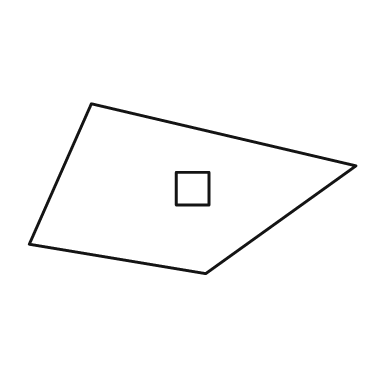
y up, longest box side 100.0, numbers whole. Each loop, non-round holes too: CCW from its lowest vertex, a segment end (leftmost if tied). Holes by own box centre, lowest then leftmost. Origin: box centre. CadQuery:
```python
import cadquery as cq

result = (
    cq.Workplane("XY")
    .moveTo(4.0, -26.0)
    .lineTo(50.0, 7.0)
    .lineTo(-31.0, 26.0)
    .lineTo(-50.0, -17.0)
    .close()
    .moveTo(-5.0, -5.0)
    .lineTo(5.0, -5.0)
    .lineTo(5.0, 5.0)
    .lineTo(-5.0, 5.0)
    .close()
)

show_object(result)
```